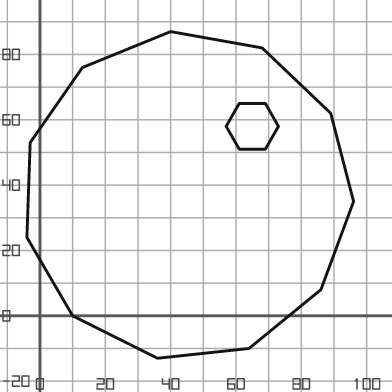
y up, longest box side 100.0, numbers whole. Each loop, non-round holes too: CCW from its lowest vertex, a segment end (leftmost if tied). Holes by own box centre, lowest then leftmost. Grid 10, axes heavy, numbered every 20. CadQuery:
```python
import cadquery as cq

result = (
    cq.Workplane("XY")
    .moveTo(36.0, -13.0)
    .lineTo(64.0, -10.0)
    .lineTo(86.0, 8.0)
    .lineTo(96.0, 35.0)
    .lineTo(89.0, 62.0)
    .lineTo(68.0, 82.0)
    .lineTo(40.0, 87.0)
    .lineTo(13.0, 76.0)
    .lineTo(-3.0, 53.0)
    .lineTo(-4.0, 24.0)
    .lineTo(10.0, 0.0)
    .close()
    .moveTo(61.0, 51.0)
    .lineTo(69.0, 51.0)
    .lineTo(73.0, 58.0)
    .lineTo(69.0, 65.0)
    .lineTo(61.0, 65.0)
    .lineTo(57.0, 58.0)
    .close()
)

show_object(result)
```